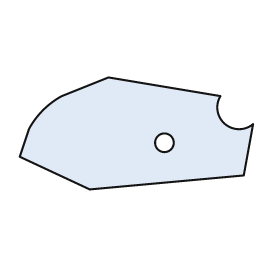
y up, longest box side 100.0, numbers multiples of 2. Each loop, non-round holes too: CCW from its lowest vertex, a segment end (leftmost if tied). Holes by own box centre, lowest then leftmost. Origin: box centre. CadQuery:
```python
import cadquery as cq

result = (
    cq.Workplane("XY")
    .moveTo(-20.0, -24.0)
    .lineTo(46.0, -18.0)
    .lineTo(50.0, 4.0)
    .threePointArc((38.0, 4.0), (36.0, 16.0))
    .lineTo(-12.0, 24.0)
    .lineTo(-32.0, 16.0)
    .threePointArc((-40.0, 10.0), (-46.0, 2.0))
    .lineTo(-50.0, -10.0)
    .close()
    .moveTo(12.0, -4.0)
    .circle(4.0)
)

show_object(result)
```